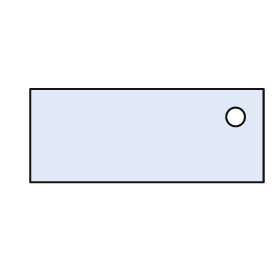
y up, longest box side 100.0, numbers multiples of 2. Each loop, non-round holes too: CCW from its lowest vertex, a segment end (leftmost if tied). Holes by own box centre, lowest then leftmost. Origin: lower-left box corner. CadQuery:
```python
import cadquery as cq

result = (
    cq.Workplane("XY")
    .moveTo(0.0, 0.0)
    .lineTo(100.0, 0.0)
    .lineTo(100.0, 40.0)
    .lineTo(0.0, 40.0)
    .close()
    .moveTo(88.0, 28.0)
    .circle(4.0)
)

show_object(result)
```